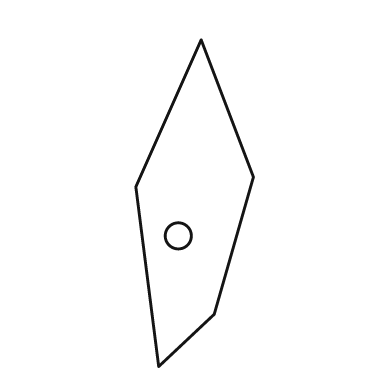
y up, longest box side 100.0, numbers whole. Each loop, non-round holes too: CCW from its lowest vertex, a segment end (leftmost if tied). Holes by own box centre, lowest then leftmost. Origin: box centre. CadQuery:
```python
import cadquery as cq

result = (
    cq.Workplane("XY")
    .moveTo(-11.0, -50.0)
    .lineTo(6.0, -34.0)
    .lineTo(18.0, 8.0)
    .lineTo(2.0, 50.0)
    .lineTo(-18.0, 5.0)
    .close()
    .moveTo(-5.0, -10.0)
    .circle(4.0)
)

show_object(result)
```